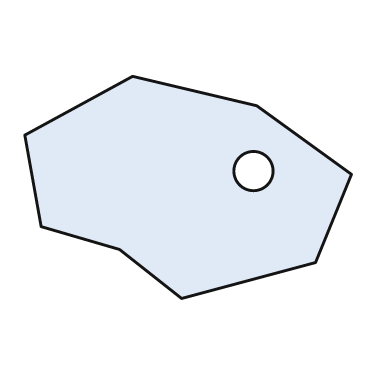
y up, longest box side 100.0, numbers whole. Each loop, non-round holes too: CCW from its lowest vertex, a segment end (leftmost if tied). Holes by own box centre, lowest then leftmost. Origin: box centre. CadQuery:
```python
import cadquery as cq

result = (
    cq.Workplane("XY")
    .moveTo(-2.0, -34.0)
    .lineTo(39.0, -23.0)
    .lineTo(50.0, 4.0)
    .lineTo(21.0, 25.0)
    .lineTo(-17.0, 34.0)
    .lineTo(-50.0, 16.0)
    .lineTo(-45.0, -12.0)
    .lineTo(-21.0, -19.0)
    .close()
    .moveTo(20.0, 5.0)
    .circle(6.0)
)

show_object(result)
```